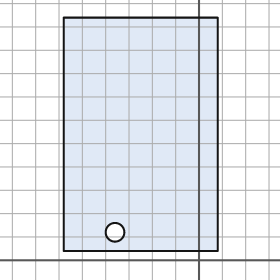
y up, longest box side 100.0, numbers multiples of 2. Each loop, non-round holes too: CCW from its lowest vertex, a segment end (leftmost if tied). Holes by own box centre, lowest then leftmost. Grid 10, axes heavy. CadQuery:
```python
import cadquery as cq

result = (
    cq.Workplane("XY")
    .moveTo(-58.0, 4.0)
    .lineTo(8.0, 4.0)
    .lineTo(8.0, 104.0)
    .lineTo(-58.0, 104.0)
    .close()
    .moveTo(-36.0, 12.0)
    .circle(4.0)
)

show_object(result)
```